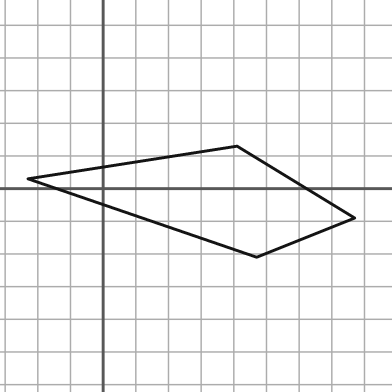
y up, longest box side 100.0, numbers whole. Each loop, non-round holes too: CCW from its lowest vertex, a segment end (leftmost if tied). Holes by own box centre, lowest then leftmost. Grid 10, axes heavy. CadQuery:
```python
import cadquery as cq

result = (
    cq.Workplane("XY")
    .moveTo(47.0, -21.0)
    .lineTo(77.0, -9.0)
    .lineTo(41.0, 13.0)
    .lineTo(-23.0, 3.0)
    .close()
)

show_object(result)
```